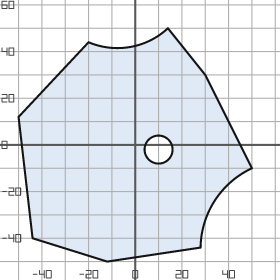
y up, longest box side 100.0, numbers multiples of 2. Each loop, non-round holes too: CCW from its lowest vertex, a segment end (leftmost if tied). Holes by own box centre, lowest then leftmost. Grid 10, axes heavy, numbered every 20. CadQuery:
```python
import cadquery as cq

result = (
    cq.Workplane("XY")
    .moveTo(-12.0, -50.0)
    .lineTo(28.0, -44.0)
    .threePointArc((34.0, -24.0), (50.0, -10.0))
    .lineTo(30.0, 30.0)
    .lineTo(14.0, 50.0)
    .threePointArc((-2.0, 42.0), (-20.0, 44.0))
    .lineTo(-50.0, 12.0)
    .lineTo(-44.0, -40.0)
    .close()
    .moveTo(10.0, -2.0)
    .circle(6.0)
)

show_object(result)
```